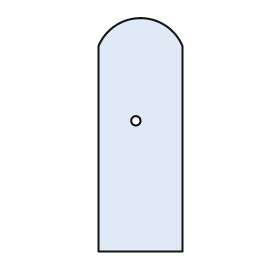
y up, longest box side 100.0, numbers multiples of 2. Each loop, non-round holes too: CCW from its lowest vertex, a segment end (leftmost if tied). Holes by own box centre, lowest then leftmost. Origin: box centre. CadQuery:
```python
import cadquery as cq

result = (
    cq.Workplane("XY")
    .moveTo(-18.0, -50.0)
    .lineTo(18.0, -50.0)
    .lineTo(18.0, 38.0)
    .threePointArc((0.0, 50.0), (-18.0, 38.0))
    .close()
    .moveTo(-2.0, 6.0)
    .circle(2.0)
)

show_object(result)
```